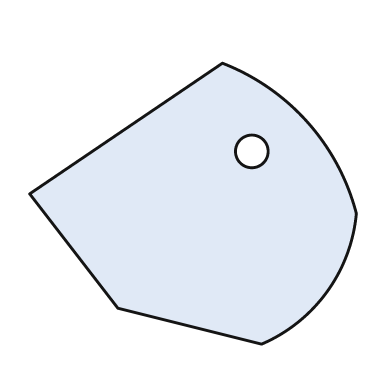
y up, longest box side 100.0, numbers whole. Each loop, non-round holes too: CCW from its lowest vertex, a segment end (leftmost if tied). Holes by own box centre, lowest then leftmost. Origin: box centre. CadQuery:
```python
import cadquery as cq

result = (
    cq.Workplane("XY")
    .moveTo(21.0, -43.0)
    .threePointArc((41.0, -27.0), (50.0, -3.0))
    .threePointArc((35.0, 25.0), (9.0, 43.0))
    .lineTo(-50.0, 3.0)
    .lineTo(-23.0, -32.0)
    .close()
    .moveTo(18.0, 16.0)
    .circle(5.0)
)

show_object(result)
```